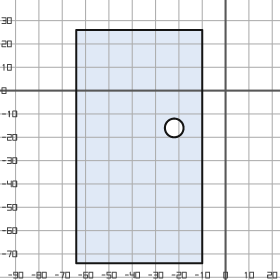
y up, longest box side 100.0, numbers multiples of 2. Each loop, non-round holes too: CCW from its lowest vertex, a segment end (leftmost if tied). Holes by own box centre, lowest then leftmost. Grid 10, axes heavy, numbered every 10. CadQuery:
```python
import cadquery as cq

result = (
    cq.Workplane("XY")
    .moveTo(-64.0, -74.0)
    .lineTo(-10.0, -74.0)
    .lineTo(-10.0, 26.0)
    .lineTo(-64.0, 26.0)
    .close()
    .moveTo(-22.0, -16.0)
    .circle(4.0)
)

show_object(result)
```